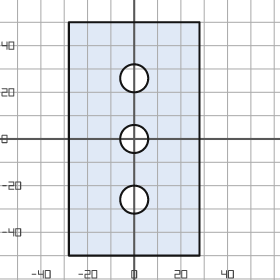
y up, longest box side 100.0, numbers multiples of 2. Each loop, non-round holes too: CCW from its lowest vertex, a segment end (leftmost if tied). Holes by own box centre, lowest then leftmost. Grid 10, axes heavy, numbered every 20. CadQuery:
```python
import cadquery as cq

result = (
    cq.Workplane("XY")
    .moveTo(-28.0, -50.0)
    .lineTo(28.0, -50.0)
    .lineTo(28.0, 50.0)
    .lineTo(-28.0, 50.0)
    .close()
    .moveTo(0.0, -26.0)
    .circle(6.0)
    .moveTo(0.0, 0.0)
    .circle(6.0)
    .moveTo(0.0, 26.0)
    .circle(6.0)
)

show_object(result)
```